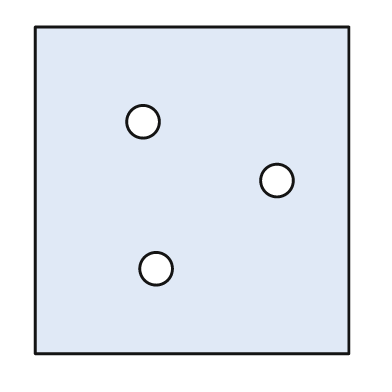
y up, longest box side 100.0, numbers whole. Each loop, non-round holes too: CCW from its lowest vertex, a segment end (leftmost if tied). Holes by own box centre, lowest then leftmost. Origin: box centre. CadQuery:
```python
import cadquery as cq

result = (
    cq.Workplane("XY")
    .moveTo(-48.0, -50.0)
    .lineTo(48.0, -50.0)
    .lineTo(48.0, 50.0)
    .lineTo(-48.0, 50.0)
    .close()
    .moveTo(-11.0, -24.0)
    .circle(5.0)
    .moveTo(26.0, 3.0)
    .circle(5.0)
    .moveTo(-15.0, 21.0)
    .circle(5.0)
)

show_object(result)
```